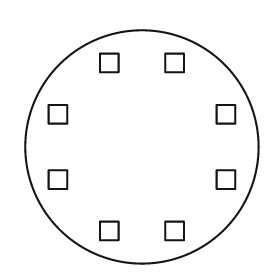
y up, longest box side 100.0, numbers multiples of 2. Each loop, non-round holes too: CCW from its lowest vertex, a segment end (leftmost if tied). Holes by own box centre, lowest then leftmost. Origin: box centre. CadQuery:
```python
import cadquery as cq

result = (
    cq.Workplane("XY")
    .moveTo(0.0, 0.0)
    .circle(50.0)
    .moveTo(-18.0, -40.0)
    .lineTo(-10.0, -40.0)
    .lineTo(-10.0, -32.0)
    .lineTo(-18.0, -32.0)
    .close()
    .moveTo(10.0, -40.0)
    .lineTo(18.0, -40.0)
    .lineTo(18.0, -32.0)
    .lineTo(10.0, -32.0)
    .close()
    .moveTo(-40.0, -18.0)
    .lineTo(-32.0, -18.0)
    .lineTo(-32.0, -10.0)
    .lineTo(-40.0, -10.0)
    .close()
    .moveTo(32.0, -18.0)
    .lineTo(40.0, -18.0)
    .lineTo(40.0, -10.0)
    .lineTo(32.0, -10.0)
    .close()
    .moveTo(-40.0, 10.0)
    .lineTo(-32.0, 10.0)
    .lineTo(-32.0, 18.0)
    .lineTo(-40.0, 18.0)
    .close()
    .moveTo(32.0, 10.0)
    .lineTo(40.0, 10.0)
    .lineTo(40.0, 18.0)
    .lineTo(32.0, 18.0)
    .close()
    .moveTo(-18.0, 32.0)
    .lineTo(-10.0, 32.0)
    .lineTo(-10.0, 40.0)
    .lineTo(-18.0, 40.0)
    .close()
    .moveTo(10.0, 32.0)
    .lineTo(18.0, 32.0)
    .lineTo(18.0, 40.0)
    .lineTo(10.0, 40.0)
    .close()
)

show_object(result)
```